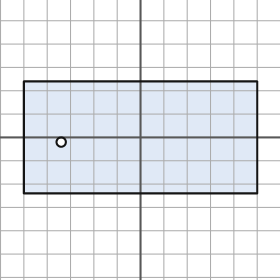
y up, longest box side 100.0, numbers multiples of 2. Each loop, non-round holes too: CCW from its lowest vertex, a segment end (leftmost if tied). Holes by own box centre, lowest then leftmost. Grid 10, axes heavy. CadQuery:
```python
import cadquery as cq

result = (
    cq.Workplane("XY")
    .moveTo(-50.0, -24.0)
    .lineTo(50.0, -24.0)
    .lineTo(50.0, 24.0)
    .lineTo(-50.0, 24.0)
    .close()
    .moveTo(-34.0, -2.0)
    .circle(2.0)
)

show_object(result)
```